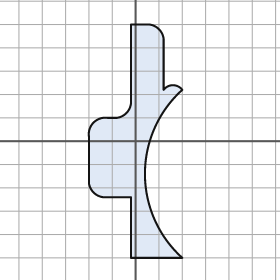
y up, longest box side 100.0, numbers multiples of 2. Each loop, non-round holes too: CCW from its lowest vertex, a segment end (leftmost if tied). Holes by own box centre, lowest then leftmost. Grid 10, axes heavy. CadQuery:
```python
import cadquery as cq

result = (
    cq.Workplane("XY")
    .moveTo(-2.0, -50.0)
    .lineTo(20.0, -50.0)
    .threePointArc((4.0, -14.0), (20.0, 22.0))
    .threePointArc((16.0, 24.0), (12.0, 22.0))
    .lineTo(12.0, 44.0)
    .threePointArc((10.0, 48.0), (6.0, 50.0))
    .lineTo(-2.0, 50.0)
    .lineTo(-2.0, 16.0)
    .threePointArc((-4.0, 12.0), (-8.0, 10.0))
    .lineTo(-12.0, 10.0)
    .threePointArc((-18.0, 8.0), (-20.0, 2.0))
    .lineTo(-20.0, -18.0)
    .threePointArc((-18.0, -22.0), (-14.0, -24.0))
    .lineTo(-2.0, -24.0)
    .close()
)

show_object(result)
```